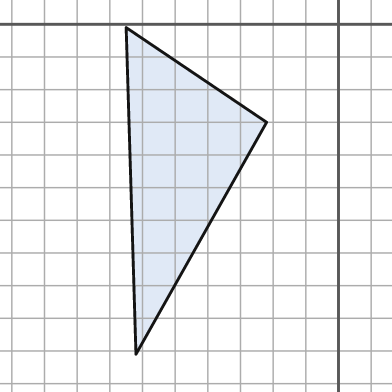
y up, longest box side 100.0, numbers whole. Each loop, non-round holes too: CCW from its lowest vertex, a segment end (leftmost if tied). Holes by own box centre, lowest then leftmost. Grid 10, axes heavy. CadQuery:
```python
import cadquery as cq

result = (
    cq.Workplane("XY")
    .moveTo(-62.0, -101.0)
    .lineTo(-22.0, -30.0)
    .lineTo(-65.0, -1.0)
    .close()
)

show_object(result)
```